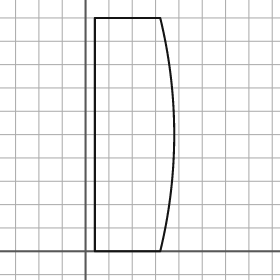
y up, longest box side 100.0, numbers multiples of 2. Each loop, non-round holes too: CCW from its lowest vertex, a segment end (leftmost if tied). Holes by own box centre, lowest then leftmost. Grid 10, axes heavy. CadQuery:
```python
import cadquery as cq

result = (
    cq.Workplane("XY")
    .moveTo(4.0, 0.0)
    .lineTo(32.0, 0.0)
    .threePointArc((38.0, 50.0), (32.0, 100.0))
    .lineTo(4.0, 100.0)
    .close()
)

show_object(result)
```